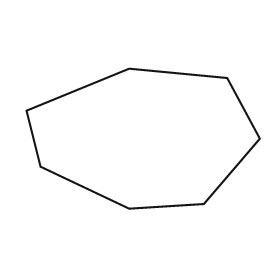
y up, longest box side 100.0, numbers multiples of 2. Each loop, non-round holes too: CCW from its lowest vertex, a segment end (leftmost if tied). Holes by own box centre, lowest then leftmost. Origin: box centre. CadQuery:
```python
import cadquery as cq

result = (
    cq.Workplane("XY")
    .moveTo(-6.0, -30.0)
    .lineTo(26.0, -28.0)
    .lineTo(50.0, 0.0)
    .lineTo(36.0, 26.0)
    .lineTo(-6.0, 30.0)
    .lineTo(-50.0, 12.0)
    .lineTo(-44.0, -12.0)
    .close()
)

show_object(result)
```